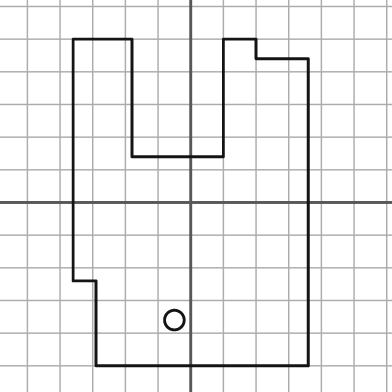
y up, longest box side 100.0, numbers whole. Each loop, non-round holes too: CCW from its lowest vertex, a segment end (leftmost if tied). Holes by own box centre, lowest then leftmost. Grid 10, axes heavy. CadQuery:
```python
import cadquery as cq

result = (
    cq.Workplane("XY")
    .moveTo(-29.0, -50.0)
    .lineTo(36.0, -50.0)
    .lineTo(36.0, 44.0)
    .lineTo(20.0, 44.0)
    .lineTo(20.0, 50.0)
    .lineTo(10.0, 50.0)
    .lineTo(10.0, 14.0)
    .lineTo(-18.0, 14.0)
    .lineTo(-18.0, 50.0)
    .lineTo(-36.0, 50.0)
    .lineTo(-36.0, -24.0)
    .lineTo(-29.0, -24.0)
    .close()
    .moveTo(-5.0, -36.0)
    .circle(3.0)
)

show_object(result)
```